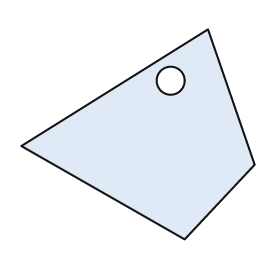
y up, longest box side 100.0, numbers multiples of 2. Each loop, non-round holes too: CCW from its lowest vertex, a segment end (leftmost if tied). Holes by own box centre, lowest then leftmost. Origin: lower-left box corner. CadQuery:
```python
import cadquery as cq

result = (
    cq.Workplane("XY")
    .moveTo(70.0, 0.0)
    .lineTo(100.0, 32.0)
    .lineTo(80.0, 90.0)
    .lineTo(0.0, 40.0)
    .close()
    .moveTo(64.0, 68.0)
    .circle(6.0)
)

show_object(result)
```